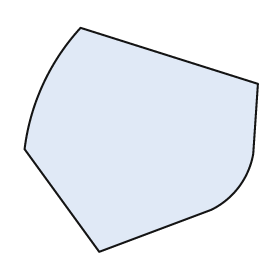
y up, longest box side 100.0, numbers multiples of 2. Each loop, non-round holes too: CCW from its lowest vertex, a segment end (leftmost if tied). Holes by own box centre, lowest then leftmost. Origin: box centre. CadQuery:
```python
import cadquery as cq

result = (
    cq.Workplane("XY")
    .moveTo(-18.0, -48.0)
    .lineTo(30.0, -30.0)
    .threePointArc((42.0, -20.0), (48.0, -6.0))
    .lineTo(50.0, 24.0)
    .lineTo(-26.0, 48.0)
    .threePointArc((-42.0, 24.0), (-50.0, -4.0))
    .close()
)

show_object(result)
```